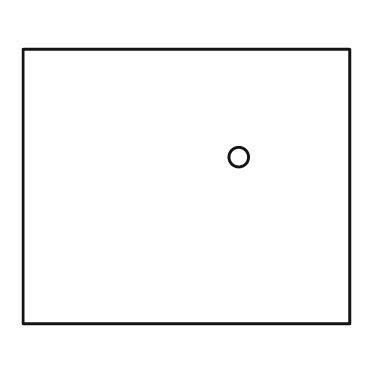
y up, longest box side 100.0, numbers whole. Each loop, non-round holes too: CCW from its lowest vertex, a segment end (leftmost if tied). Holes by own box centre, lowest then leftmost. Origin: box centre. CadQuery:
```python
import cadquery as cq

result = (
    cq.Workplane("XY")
    .moveTo(-50.0, -42.0)
    .lineTo(50.0, -42.0)
    .lineTo(50.0, 42.0)
    .lineTo(-50.0, 42.0)
    .close()
    .moveTo(16.0, 9.0)
    .circle(3.0)
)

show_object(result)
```